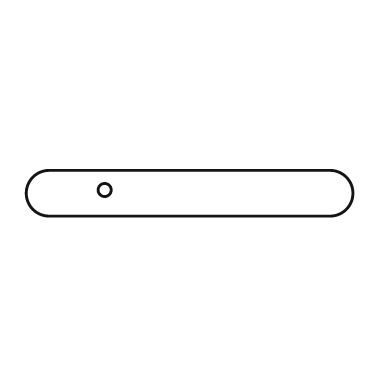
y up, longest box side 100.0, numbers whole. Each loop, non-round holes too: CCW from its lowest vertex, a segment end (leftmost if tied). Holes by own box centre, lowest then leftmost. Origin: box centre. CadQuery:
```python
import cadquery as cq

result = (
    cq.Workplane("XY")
    .moveTo(-43.0, -7.0)
    .lineTo(43.0, -7.0)
    .threePointArc((50.0, 0.0), (43.0, 7.0))
    .lineTo(-43.0, 7.0)
    .threePointArc((-50.0, 0.0), (-43.0, -7.0))
    .close()
    .moveTo(-26.0, 1.0)
    .circle(2.0)
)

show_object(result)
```